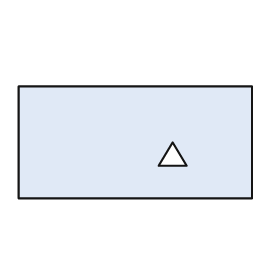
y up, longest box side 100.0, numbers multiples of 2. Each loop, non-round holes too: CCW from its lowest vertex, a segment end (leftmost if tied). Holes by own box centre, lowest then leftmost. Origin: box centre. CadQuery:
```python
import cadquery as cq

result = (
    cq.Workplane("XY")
    .moveTo(-50.0, -24.0)
    .lineTo(50.0, -24.0)
    .lineTo(50.0, 24.0)
    .lineTo(-50.0, 24.0)
    .close()
    .moveTo(10.0, -10.0)
    .lineTo(22.0, -10.0)
    .lineTo(16.0, 0.0)
    .close()
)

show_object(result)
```